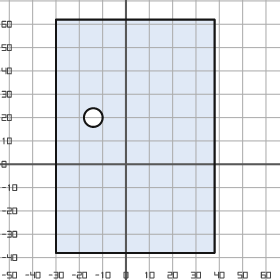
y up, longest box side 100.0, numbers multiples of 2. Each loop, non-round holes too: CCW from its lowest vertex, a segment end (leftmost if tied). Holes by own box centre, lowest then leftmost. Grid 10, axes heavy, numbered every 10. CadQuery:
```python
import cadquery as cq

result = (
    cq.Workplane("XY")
    .moveTo(-30.0, -38.0)
    .lineTo(38.0, -38.0)
    .lineTo(38.0, 62.0)
    .lineTo(-30.0, 62.0)
    .close()
    .moveTo(-14.0, 20.0)
    .circle(4.0)
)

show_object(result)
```